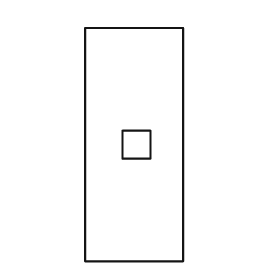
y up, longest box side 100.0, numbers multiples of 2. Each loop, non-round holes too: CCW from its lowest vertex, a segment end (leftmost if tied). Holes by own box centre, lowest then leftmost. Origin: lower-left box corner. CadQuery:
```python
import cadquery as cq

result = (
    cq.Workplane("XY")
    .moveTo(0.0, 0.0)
    .lineTo(42.0, 0.0)
    .lineTo(42.0, 100.0)
    .lineTo(0.0, 100.0)
    .close()
    .moveTo(16.0, 44.0)
    .lineTo(28.0, 44.0)
    .lineTo(28.0, 56.0)
    .lineTo(16.0, 56.0)
    .close()
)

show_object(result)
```